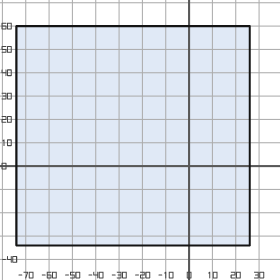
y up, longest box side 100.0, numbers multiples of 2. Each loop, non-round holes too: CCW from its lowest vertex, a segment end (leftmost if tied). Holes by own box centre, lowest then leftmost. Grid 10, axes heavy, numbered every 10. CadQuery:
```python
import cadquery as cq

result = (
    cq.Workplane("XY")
    .moveTo(-74.0, -34.0)
    .lineTo(26.0, -34.0)
    .lineTo(26.0, 60.0)
    .lineTo(-74.0, 60.0)
    .close()
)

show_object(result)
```